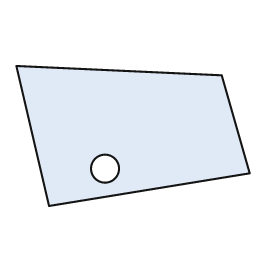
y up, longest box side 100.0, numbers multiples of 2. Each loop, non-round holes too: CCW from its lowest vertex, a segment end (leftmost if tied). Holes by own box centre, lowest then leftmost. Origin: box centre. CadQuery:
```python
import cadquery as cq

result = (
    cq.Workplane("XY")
    .moveTo(-36.0, -30.0)
    .lineTo(50.0, -16.0)
    .lineTo(38.0, 26.0)
    .lineTo(-50.0, 30.0)
    .close()
    .moveTo(-12.0, -14.0)
    .circle(6.0)
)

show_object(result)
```